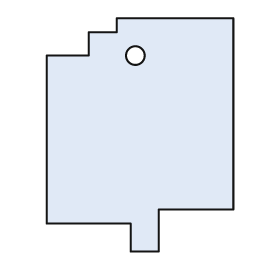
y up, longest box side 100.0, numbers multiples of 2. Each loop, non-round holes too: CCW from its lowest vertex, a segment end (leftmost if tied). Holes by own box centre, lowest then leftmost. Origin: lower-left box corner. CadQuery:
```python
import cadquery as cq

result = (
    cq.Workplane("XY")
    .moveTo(36.0, 0.0)
    .lineTo(48.0, 0.0)
    .lineTo(48.0, 18.0)
    .lineTo(80.0, 18.0)
    .lineTo(80.0, 100.0)
    .lineTo(30.0, 100.0)
    .lineTo(30.0, 94.0)
    .lineTo(18.0, 94.0)
    .lineTo(18.0, 84.0)
    .lineTo(0.0, 84.0)
    .lineTo(0.0, 12.0)
    .lineTo(36.0, 12.0)
    .close()
    .moveTo(38.0, 84.0)
    .circle(4.0)
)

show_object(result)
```